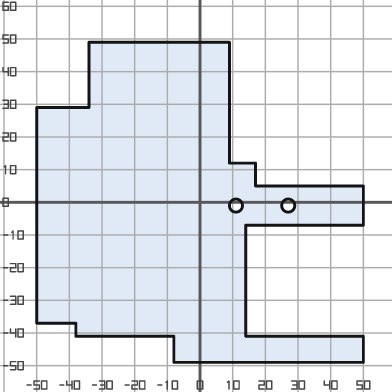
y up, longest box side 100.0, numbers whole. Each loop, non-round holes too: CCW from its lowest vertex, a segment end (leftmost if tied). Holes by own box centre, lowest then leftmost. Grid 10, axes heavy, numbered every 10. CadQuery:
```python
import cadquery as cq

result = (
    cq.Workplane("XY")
    .moveTo(-8.0, -49.0)
    .lineTo(50.0, -49.0)
    .lineTo(50.0, -41.0)
    .lineTo(14.0, -41.0)
    .lineTo(14.0, -7.0)
    .lineTo(50.0, -7.0)
    .lineTo(50.0, 5.0)
    .lineTo(17.0, 5.0)
    .lineTo(17.0, 12.0)
    .lineTo(9.0, 12.0)
    .lineTo(9.0, 49.0)
    .lineTo(-34.0, 49.0)
    .lineTo(-34.0, 29.0)
    .lineTo(-50.0, 29.0)
    .lineTo(-50.0, -37.0)
    .lineTo(-38.0, -37.0)
    .lineTo(-38.0, -41.0)
    .lineTo(-8.0, -41.0)
    .close()
    .moveTo(11.0, -1.0)
    .circle(2.0)
    .moveTo(27.0, -1.0)
    .circle(2.0)
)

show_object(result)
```